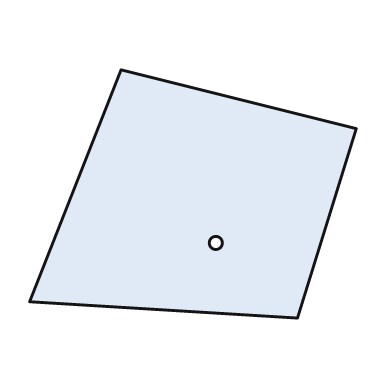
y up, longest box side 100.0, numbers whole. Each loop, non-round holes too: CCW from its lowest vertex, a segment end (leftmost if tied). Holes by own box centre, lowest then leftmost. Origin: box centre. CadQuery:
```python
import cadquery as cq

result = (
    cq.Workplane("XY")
    .moveTo(32.0, -38.0)
    .lineTo(50.0, 20.0)
    .lineTo(-22.0, 38.0)
    .lineTo(-50.0, -33.0)
    .close()
    .moveTo(7.0, -15.0)
    .circle(2.0)
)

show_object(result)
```